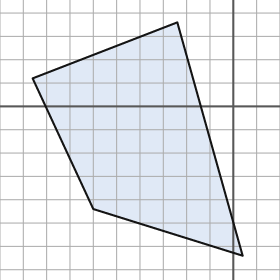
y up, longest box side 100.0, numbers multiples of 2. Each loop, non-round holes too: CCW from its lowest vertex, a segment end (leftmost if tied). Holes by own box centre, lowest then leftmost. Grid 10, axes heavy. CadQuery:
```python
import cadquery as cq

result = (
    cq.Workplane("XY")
    .moveTo(4.0, -64.0)
    .lineTo(-24.0, 36.0)
    .lineTo(-86.0, 12.0)
    .lineTo(-60.0, -44.0)
    .close()
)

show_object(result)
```